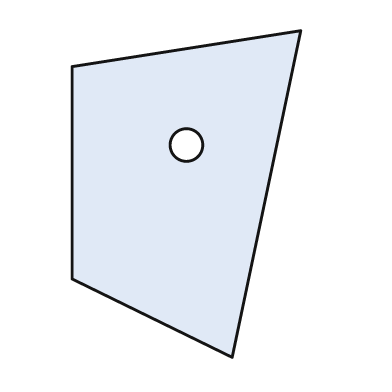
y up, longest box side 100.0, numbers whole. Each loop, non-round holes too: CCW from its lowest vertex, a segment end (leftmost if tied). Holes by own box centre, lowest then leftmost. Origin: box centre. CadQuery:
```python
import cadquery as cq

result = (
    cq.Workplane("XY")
    .moveTo(14.0, -50.0)
    .lineTo(35.0, 50.0)
    .lineTo(-35.0, 39.0)
    .lineTo(-35.0, -26.0)
    .close()
    .moveTo(0.0, 15.0)
    .circle(5.0)
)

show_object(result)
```